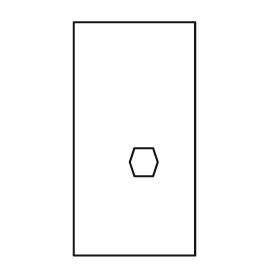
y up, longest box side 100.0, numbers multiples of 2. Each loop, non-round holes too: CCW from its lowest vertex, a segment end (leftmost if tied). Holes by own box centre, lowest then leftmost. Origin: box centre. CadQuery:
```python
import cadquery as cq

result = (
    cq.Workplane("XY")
    .moveTo(-26.0, -50.0)
    .lineTo(26.0, -50.0)
    .lineTo(26.0, 50.0)
    .lineTo(-26.0, 50.0)
    .close()
    .moveTo(0.0, -16.0)
    .lineTo(8.0, -16.0)
    .lineTo(10.0, -10.0)
    .lineTo(8.0, -4.0)
    .lineTo(0.0, -4.0)
    .lineTo(-2.0, -10.0)
    .close()
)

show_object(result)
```